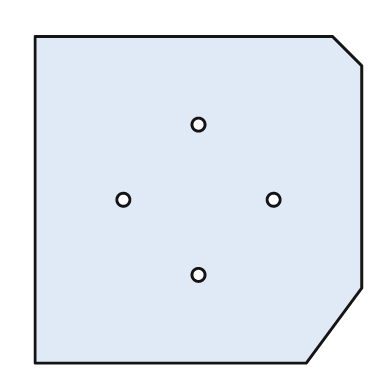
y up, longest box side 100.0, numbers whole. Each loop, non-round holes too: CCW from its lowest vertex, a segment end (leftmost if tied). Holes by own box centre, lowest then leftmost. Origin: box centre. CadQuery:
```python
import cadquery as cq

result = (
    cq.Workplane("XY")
    .moveTo(-50.0, -50.0)
    .lineTo(33.0, -50.0)
    .lineTo(50.0, -27.0)
    .lineTo(50.0, 41.0)
    .lineTo(41.0, 50.0)
    .lineTo(-50.0, 50.0)
    .close()
    .moveTo(0.0, -23.0)
    .circle(2.0)
    .moveTo(-23.0, 0.0)
    .circle(2.0)
    .moveTo(23.0, 0.0)
    .circle(2.0)
    .moveTo(0.0, 23.0)
    .circle(2.0)
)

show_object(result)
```